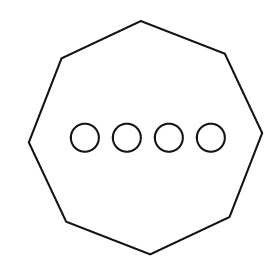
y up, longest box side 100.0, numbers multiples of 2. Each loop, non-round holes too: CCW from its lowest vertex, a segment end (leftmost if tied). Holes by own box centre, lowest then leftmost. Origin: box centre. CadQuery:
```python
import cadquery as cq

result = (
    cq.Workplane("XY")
    .moveTo(2.0, -50.0)
    .lineTo(36.0, -34.0)
    .lineTo(50.0, 2.0)
    .lineTo(34.0, 36.0)
    .lineTo(-2.0, 50.0)
    .lineTo(-36.0, 34.0)
    .lineTo(-50.0, -2.0)
    .lineTo(-34.0, -36.0)
    .close()
    .moveTo(-26.0, 0.0)
    .circle(6.0)
    .moveTo(-8.0, 0.0)
    .circle(6.0)
    .moveTo(10.0, 0.0)
    .circle(6.0)
    .moveTo(28.0, 0.0)
    .circle(6.0)
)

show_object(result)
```